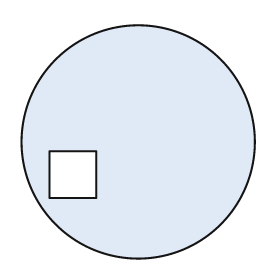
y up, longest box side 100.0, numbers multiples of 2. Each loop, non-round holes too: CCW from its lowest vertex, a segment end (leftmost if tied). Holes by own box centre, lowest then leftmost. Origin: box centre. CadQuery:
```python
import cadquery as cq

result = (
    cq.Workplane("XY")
    .moveTo(0.0, 0.0)
    .circle(50.0)
    .moveTo(-38.0, -24.0)
    .lineTo(-18.0, -24.0)
    .lineTo(-18.0, -4.0)
    .lineTo(-38.0, -4.0)
    .close()
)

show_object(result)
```